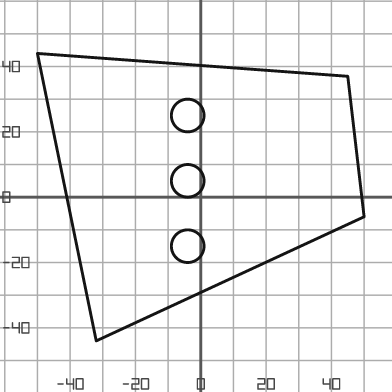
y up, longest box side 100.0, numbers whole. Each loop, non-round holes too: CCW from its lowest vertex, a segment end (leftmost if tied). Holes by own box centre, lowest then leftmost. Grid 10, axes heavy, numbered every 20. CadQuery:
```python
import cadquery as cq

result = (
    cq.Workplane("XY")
    .moveTo(-32.0, -44.0)
    .lineTo(50.0, -6.0)
    .lineTo(45.0, 37.0)
    .lineTo(-50.0, 44.0)
    .close()
    .moveTo(-4.0, -15.0)
    .circle(5.0)
    .moveTo(-4.0, 5.0)
    .circle(5.0)
    .moveTo(-4.0, 25.0)
    .circle(5.0)
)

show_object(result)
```